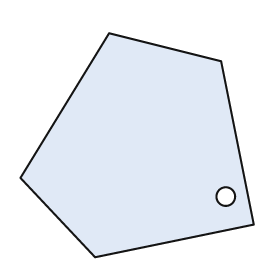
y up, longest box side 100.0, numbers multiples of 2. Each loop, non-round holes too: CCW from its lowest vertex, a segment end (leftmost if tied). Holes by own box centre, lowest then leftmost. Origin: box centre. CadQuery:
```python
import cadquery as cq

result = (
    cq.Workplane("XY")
    .moveTo(-18.0, -48.0)
    .lineTo(50.0, -34.0)
    .lineTo(36.0, 36.0)
    .lineTo(-12.0, 48.0)
    .lineTo(-50.0, -14.0)
    .close()
    .moveTo(38.0, -22.0)
    .circle(4.0)
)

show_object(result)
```